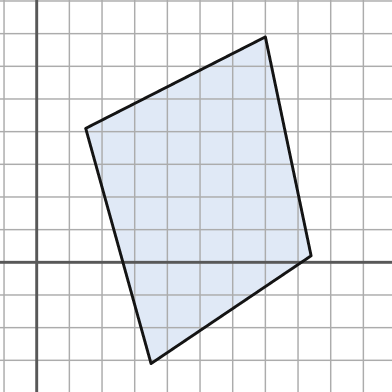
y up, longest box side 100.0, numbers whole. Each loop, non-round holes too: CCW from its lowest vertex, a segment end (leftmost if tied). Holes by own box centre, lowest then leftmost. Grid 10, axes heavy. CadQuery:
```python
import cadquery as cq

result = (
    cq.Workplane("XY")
    .moveTo(35.0, -31.0)
    .lineTo(84.0, 2.0)
    .lineTo(70.0, 69.0)
    .lineTo(15.0, 41.0)
    .close()
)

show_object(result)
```